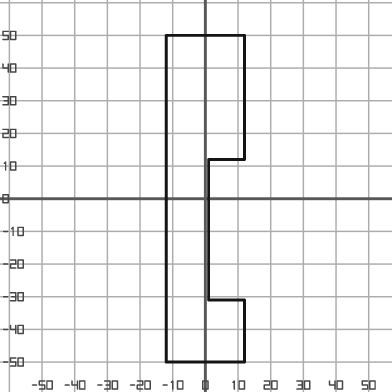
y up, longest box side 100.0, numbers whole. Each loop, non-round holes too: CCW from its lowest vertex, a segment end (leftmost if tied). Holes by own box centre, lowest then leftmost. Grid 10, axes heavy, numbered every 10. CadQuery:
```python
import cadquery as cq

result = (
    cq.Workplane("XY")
    .moveTo(-12.0, -50.0)
    .lineTo(12.0, -50.0)
    .lineTo(12.0, -31.0)
    .lineTo(1.0, -31.0)
    .lineTo(1.0, 12.0)
    .lineTo(12.0, 12.0)
    .lineTo(12.0, 50.0)
    .lineTo(-12.0, 50.0)
    .close()
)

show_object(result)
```